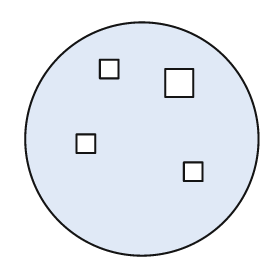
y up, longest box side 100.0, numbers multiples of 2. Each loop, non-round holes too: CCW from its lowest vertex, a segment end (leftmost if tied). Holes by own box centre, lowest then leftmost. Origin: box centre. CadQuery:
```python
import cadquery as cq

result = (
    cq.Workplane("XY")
    .moveTo(0.0, 0.0)
    .circle(50.0)
    .moveTo(18.0, -18.0)
    .lineTo(26.0, -18.0)
    .lineTo(26.0, -10.0)
    .lineTo(18.0, -10.0)
    .close()
    .moveTo(-28.0, -6.0)
    .lineTo(-20.0, -6.0)
    .lineTo(-20.0, 2.0)
    .lineTo(-28.0, 2.0)
    .close()
    .moveTo(10.0, 18.0)
    .lineTo(22.0, 18.0)
    .lineTo(22.0, 30.0)
    .lineTo(10.0, 30.0)
    .close()
    .moveTo(-18.0, 26.0)
    .lineTo(-10.0, 26.0)
    .lineTo(-10.0, 34.0)
    .lineTo(-18.0, 34.0)
    .close()
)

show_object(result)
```